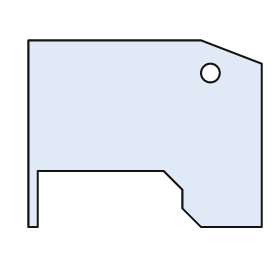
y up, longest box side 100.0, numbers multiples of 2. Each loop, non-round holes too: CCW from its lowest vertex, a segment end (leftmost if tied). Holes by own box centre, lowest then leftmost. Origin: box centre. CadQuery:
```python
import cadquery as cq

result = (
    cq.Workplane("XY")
    .moveTo(-50.0, -40.0)
    .lineTo(-46.0, -40.0)
    .lineTo(-46.0, -16.0)
    .lineTo(8.0, -16.0)
    .lineTo(16.0, -24.0)
    .lineTo(16.0, -32.0)
    .lineTo(24.0, -40.0)
    .lineTo(50.0, -40.0)
    .lineTo(50.0, 30.0)
    .lineTo(24.0, 40.0)
    .lineTo(-50.0, 40.0)
    .close()
    .moveTo(28.0, 26.0)
    .circle(4.0)
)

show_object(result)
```